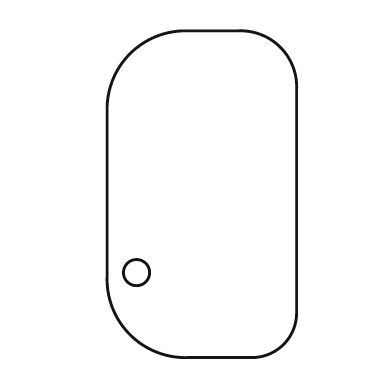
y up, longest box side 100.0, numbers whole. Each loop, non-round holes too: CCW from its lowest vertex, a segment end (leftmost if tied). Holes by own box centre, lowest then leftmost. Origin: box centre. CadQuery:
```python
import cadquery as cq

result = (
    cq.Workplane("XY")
    .moveTo(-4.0, -50.0)
    .lineTo(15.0, -50.0)
    .threePointArc((25.0, -46.0), (29.0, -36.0))
    .lineTo(29.0, 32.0)
    .threePointArc((24.0, 45.0), (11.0, 50.0))
    .lineTo(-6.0, 50.0)
    .threePointArc((-22.0, 43.0), (-29.0, 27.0))
    .lineTo(-29.0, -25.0)
    .threePointArc((-22.0, -43.0), (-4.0, -50.0))
    .close()
    .moveTo(-20.0, -24.0)
    .circle(4.0)
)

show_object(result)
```